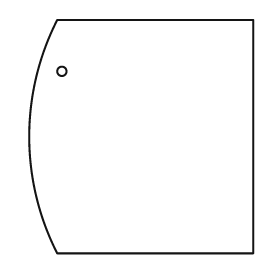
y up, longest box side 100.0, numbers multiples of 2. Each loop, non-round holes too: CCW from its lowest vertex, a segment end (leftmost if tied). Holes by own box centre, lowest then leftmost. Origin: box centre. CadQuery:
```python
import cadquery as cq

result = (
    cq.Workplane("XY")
    .moveTo(-36.0, -50.0)
    .lineTo(48.0, -50.0)
    .lineTo(48.0, 50.0)
    .lineTo(-36.0, 50.0)
    .threePointArc((-48.0, 0.0), (-36.0, -50.0))
    .close()
    .moveTo(-34.0, 28.0)
    .circle(2.0)
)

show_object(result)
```